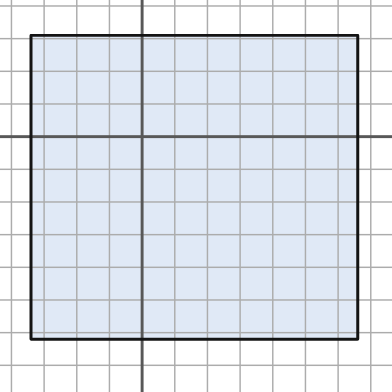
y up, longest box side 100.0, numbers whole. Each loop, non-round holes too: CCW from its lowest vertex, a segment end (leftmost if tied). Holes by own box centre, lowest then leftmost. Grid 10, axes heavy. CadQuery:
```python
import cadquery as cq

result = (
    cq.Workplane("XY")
    .moveTo(-34.0, -62.0)
    .lineTo(66.0, -62.0)
    .lineTo(66.0, 31.0)
    .lineTo(-34.0, 31.0)
    .close()
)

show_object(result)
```